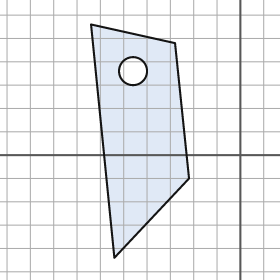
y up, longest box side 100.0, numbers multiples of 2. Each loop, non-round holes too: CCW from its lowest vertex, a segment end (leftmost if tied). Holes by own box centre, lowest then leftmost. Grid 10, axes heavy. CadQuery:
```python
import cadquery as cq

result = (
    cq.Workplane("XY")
    .moveTo(-54.0, -44.0)
    .lineTo(-22.0, -10.0)
    .lineTo(-28.0, 48.0)
    .lineTo(-64.0, 56.0)
    .close()
    .moveTo(-46.0, 36.0)
    .circle(6.0)
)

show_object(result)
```